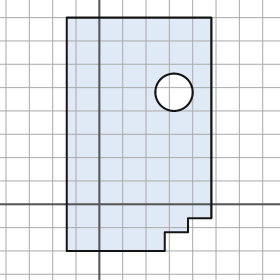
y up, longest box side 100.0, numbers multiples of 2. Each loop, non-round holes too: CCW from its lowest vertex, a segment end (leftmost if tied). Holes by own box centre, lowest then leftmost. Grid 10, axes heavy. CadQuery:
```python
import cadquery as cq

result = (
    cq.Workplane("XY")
    .moveTo(-14.0, -20.0)
    .lineTo(28.0, -20.0)
    .lineTo(28.0, -12.0)
    .lineTo(38.0, -12.0)
    .lineTo(38.0, -6.0)
    .lineTo(48.0, -6.0)
    .lineTo(48.0, 80.0)
    .lineTo(-14.0, 80.0)
    .close()
    .moveTo(32.0, 48.0)
    .circle(8.0)
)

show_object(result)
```